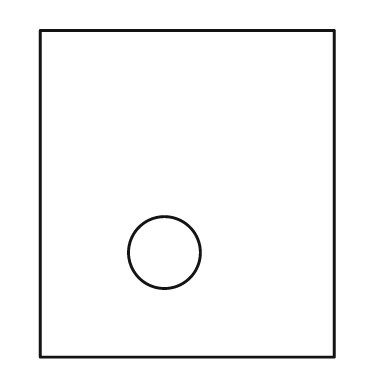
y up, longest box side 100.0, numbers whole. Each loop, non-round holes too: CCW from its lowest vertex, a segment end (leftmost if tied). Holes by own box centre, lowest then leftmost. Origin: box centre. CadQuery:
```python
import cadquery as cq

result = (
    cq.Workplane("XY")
    .moveTo(-45.0, -50.0)
    .lineTo(45.0, -50.0)
    .lineTo(45.0, 50.0)
    .lineTo(-45.0, 50.0)
    .close()
    .moveTo(-7.0, -18.0)
    .circle(11.0)
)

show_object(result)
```